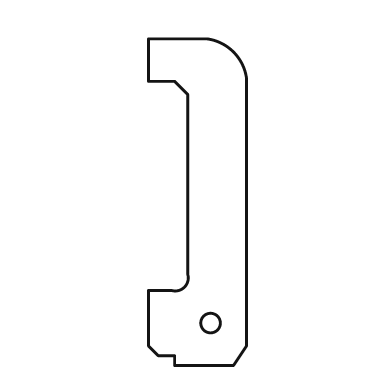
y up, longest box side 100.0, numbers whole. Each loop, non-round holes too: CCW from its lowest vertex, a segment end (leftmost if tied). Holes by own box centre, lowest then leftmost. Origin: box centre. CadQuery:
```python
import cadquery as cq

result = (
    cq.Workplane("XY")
    .moveTo(-7.0, -50.0)
    .lineTo(11.0, -50.0)
    .lineTo(15.0, -44.0)
    .lineTo(15.0, 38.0)
    .threePointArc((11.0, 46.0), (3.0, 50.0))
    .lineTo(-15.0, 50.0)
    .lineTo(-15.0, 37.0)
    .lineTo(-7.0, 37.0)
    .lineTo(-3.0, 33.0)
    .lineTo(-3.0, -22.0)
    .threePointArc((-4.0, -26.0), (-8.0, -27.0))
    .lineTo(-15.0, -27.0)
    .lineTo(-15.0, -44.0)
    .lineTo(-12.0, -47.0)
    .lineTo(-7.0, -47.0)
    .close()
    .moveTo(4.0, -37.0)
    .circle(3.0)
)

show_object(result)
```